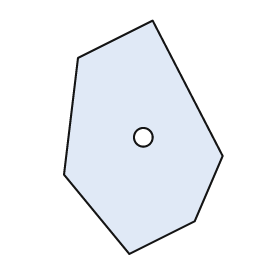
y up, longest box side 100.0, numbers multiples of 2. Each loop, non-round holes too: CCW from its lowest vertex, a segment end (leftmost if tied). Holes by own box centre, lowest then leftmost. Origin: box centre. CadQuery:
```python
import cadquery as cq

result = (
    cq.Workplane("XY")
    .moveTo(-6.0, -50.0)
    .lineTo(22.0, -36.0)
    .lineTo(34.0, -8.0)
    .lineTo(4.0, 50.0)
    .lineTo(-28.0, 34.0)
    .lineTo(-34.0, -16.0)
    .close()
    .moveTo(0.0, 0.0)
    .circle(4.0)
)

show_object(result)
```